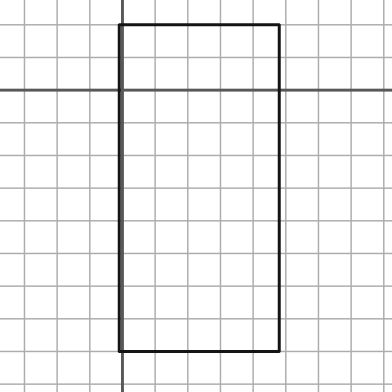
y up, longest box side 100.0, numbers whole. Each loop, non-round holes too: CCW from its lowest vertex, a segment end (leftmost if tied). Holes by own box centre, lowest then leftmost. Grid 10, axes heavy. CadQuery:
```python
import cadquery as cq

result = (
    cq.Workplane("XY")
    .moveTo(-1.0, -80.0)
    .lineTo(48.0, -80.0)
    .lineTo(48.0, 20.0)
    .lineTo(-1.0, 20.0)
    .close()
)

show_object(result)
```